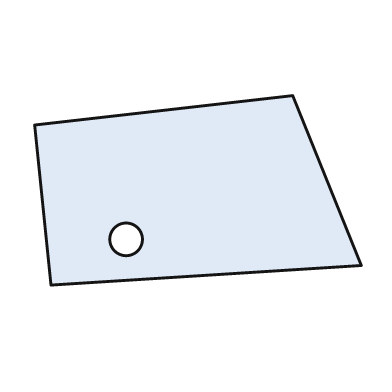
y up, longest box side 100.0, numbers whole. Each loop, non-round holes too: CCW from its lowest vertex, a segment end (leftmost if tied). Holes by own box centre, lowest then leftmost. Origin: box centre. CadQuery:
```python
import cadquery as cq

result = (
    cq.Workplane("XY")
    .moveTo(-45.0, -29.0)
    .lineTo(50.0, -23.0)
    .lineTo(29.0, 29.0)
    .lineTo(-50.0, 20.0)
    .close()
    .moveTo(-22.0, -15.0)
    .circle(5.0)
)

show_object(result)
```